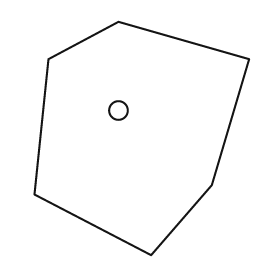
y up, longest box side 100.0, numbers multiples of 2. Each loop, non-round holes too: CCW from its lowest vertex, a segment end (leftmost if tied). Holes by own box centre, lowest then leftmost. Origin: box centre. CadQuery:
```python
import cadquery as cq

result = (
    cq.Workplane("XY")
    .moveTo(4.0, -50.0)
    .lineTo(30.0, -20.0)
    .lineTo(46.0, 34.0)
    .lineTo(-10.0, 50.0)
    .lineTo(-40.0, 34.0)
    .lineTo(-46.0, -24.0)
    .close()
    .moveTo(-10.0, 12.0)
    .circle(4.0)
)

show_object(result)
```